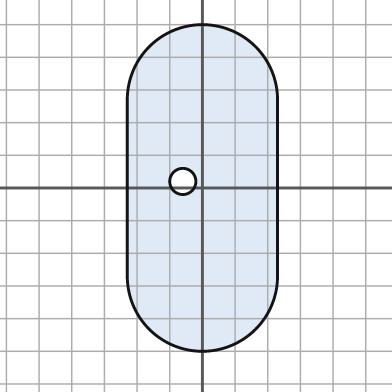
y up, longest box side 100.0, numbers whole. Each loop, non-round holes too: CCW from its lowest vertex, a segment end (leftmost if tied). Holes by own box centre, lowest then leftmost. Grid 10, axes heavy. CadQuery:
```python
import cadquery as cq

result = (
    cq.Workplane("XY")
    .moveTo(-23.0, -27.0)
    .threePointArc((0.0, -50.0), (23.0, -27.0))
    .lineTo(23.0, 27.0)
    .threePointArc((0.0, 50.0), (-23.0, 27.0))
    .close()
    .moveTo(-6.0, 2.0)
    .circle(4.0)
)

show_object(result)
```